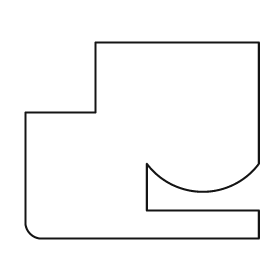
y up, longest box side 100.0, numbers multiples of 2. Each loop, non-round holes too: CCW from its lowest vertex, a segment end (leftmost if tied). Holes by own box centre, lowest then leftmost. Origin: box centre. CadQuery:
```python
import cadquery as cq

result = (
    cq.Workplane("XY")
    .moveTo(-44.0, -42.0)
    .lineTo(50.0, -42.0)
    .lineTo(50.0, -30.0)
    .lineTo(2.0, -30.0)
    .lineTo(2.0, -10.0)
    .threePointArc((26.0, -22.0), (50.0, -10.0))
    .lineTo(50.0, 42.0)
    .lineTo(-20.0, 42.0)
    .lineTo(-20.0, 12.0)
    .lineTo(-50.0, 12.0)
    .lineTo(-50.0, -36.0)
    .threePointArc((-48.0, -40.0), (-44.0, -42.0))
    .close()
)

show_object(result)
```